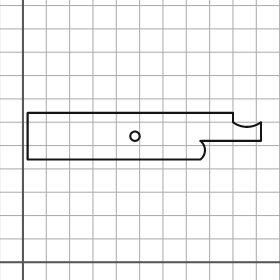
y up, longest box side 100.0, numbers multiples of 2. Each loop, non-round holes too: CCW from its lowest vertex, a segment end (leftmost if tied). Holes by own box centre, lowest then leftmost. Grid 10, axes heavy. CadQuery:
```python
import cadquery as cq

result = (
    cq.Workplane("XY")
    .moveTo(2.0, 44.0)
    .lineTo(76.0, 44.0)
    .threePointArc((78.0, 48.0), (76.0, 52.0))
    .lineTo(102.0, 52.0)
    .lineTo(102.0, 60.0)
    .threePointArc((96.0, 58.0), (90.0, 60.0))
    .lineTo(90.0, 64.0)
    .lineTo(2.0, 64.0)
    .close()
    .moveTo(48.0, 54.0)
    .circle(2.0)
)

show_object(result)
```